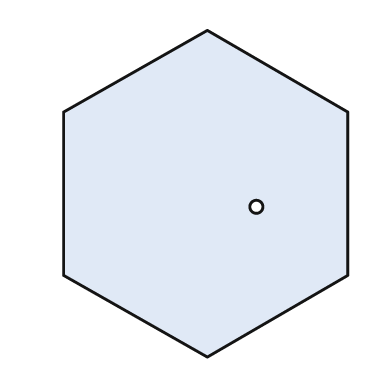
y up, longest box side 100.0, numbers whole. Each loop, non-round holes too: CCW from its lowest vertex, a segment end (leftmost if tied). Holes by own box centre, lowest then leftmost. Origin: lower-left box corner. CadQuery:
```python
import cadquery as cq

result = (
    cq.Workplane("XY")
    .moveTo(44.0, 0.0)
    .lineTo(87.0, 25.0)
    .lineTo(87.0, 75.0)
    .lineTo(44.0, 100.0)
    .lineTo(0.0, 75.0)
    .lineTo(0.0, 25.0)
    .close()
    .moveTo(59.0, 46.0)
    .circle(2.0)
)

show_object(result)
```